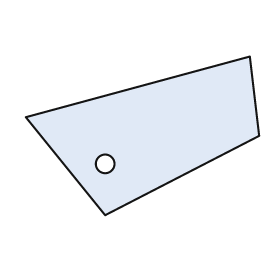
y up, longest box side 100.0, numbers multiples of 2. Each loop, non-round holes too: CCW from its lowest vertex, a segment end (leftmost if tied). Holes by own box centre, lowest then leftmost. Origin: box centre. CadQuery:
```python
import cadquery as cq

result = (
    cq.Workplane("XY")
    .moveTo(-16.0, -34.0)
    .lineTo(50.0, 0.0)
    .lineTo(46.0, 34.0)
    .lineTo(-50.0, 8.0)
    .close()
    .moveTo(-16.0, -12.0)
    .circle(4.0)
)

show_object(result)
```